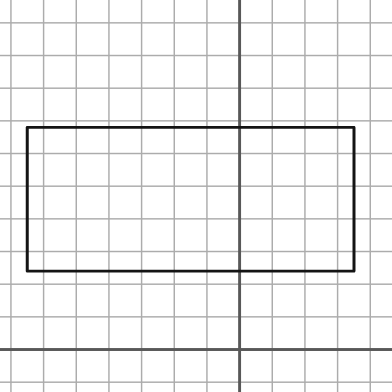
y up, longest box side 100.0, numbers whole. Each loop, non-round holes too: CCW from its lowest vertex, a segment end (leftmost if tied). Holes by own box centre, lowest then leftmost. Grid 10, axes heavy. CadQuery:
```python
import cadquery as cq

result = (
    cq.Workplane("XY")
    .moveTo(-65.0, 24.0)
    .lineTo(35.0, 24.0)
    .lineTo(35.0, 68.0)
    .lineTo(-65.0, 68.0)
    .close()
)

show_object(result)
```